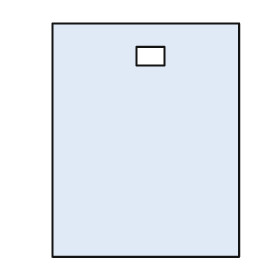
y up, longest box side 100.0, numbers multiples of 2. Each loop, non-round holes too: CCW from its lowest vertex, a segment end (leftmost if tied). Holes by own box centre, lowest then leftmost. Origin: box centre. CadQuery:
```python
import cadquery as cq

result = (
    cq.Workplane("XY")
    .moveTo(-40.0, -50.0)
    .lineTo(40.0, -50.0)
    .lineTo(40.0, 50.0)
    .lineTo(-40.0, 50.0)
    .close()
    .moveTo(-4.0, 32.0)
    .lineTo(8.0, 32.0)
    .lineTo(8.0, 40.0)
    .lineTo(-4.0, 40.0)
    .close()
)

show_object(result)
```